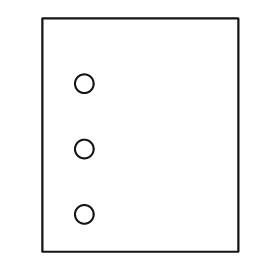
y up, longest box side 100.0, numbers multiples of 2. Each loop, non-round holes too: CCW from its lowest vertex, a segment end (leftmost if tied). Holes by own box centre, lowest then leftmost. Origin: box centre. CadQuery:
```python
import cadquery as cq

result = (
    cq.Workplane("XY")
    .moveTo(-42.0, -50.0)
    .lineTo(42.0, -50.0)
    .lineTo(42.0, 50.0)
    .lineTo(-42.0, 50.0)
    .close()
    .moveTo(-24.0, -34.0)
    .circle(4.0)
    .moveTo(-24.0, -6.0)
    .circle(4.0)
    .moveTo(-24.0, 22.0)
    .circle(4.0)
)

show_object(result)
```